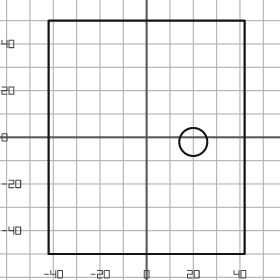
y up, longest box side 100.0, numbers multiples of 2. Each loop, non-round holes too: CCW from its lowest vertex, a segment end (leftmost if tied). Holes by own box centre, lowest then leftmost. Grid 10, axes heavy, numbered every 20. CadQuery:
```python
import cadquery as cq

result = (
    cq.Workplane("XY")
    .moveTo(-42.0, -50.0)
    .lineTo(42.0, -50.0)
    .lineTo(42.0, 50.0)
    .lineTo(-42.0, 50.0)
    .close()
    .moveTo(20.0, -2.0)
    .circle(6.0)
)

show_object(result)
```